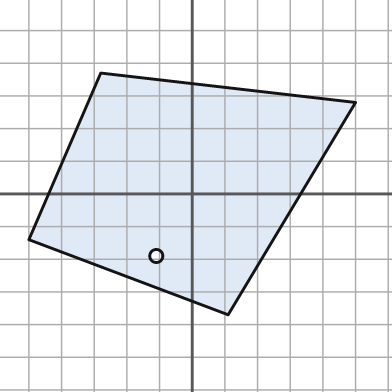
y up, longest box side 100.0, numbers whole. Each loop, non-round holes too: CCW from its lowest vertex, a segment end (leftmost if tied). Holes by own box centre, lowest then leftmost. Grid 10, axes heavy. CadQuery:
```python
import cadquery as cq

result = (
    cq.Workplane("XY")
    .moveTo(11.0, -37.0)
    .lineTo(50.0, 28.0)
    .lineTo(-28.0, 37.0)
    .lineTo(-50.0, -14.0)
    .close()
    .moveTo(-11.0, -19.0)
    .circle(2.0)
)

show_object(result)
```